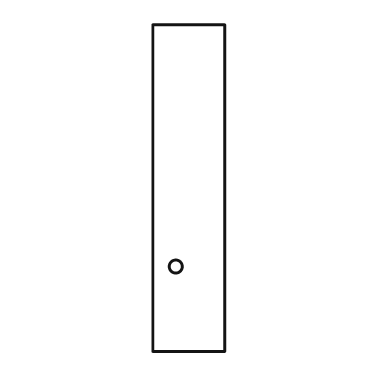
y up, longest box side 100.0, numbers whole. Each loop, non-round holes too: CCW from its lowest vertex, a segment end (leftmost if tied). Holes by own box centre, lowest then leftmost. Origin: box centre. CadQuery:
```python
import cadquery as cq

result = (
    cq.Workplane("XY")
    .moveTo(-11.0, -50.0)
    .lineTo(11.0, -50.0)
    .lineTo(11.0, 50.0)
    .lineTo(-11.0, 50.0)
    .close()
    .moveTo(-4.0, -24.0)
    .circle(2.0)
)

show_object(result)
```